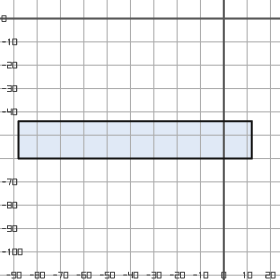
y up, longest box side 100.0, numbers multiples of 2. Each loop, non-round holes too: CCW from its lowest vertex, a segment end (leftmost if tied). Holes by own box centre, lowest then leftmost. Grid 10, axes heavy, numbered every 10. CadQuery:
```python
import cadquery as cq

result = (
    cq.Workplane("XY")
    .moveTo(-88.0, -60.0)
    .lineTo(12.0, -60.0)
    .lineTo(12.0, -44.0)
    .lineTo(-88.0, -44.0)
    .close()
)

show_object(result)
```